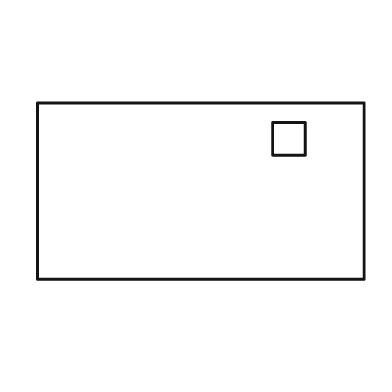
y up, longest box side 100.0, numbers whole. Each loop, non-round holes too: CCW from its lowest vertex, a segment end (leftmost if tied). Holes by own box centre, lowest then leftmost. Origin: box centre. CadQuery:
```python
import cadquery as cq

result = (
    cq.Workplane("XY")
    .moveTo(-50.0, -27.0)
    .lineTo(50.0, -27.0)
    .lineTo(50.0, 27.0)
    .lineTo(-50.0, 27.0)
    .close()
    .moveTo(22.0, 11.0)
    .lineTo(32.0, 11.0)
    .lineTo(32.0, 21.0)
    .lineTo(22.0, 21.0)
    .close()
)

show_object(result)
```